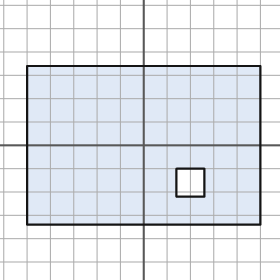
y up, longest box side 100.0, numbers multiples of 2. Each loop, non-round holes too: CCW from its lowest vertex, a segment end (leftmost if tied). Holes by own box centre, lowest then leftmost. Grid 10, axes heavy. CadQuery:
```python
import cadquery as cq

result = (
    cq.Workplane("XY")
    .moveTo(-50.0, -34.0)
    .lineTo(50.0, -34.0)
    .lineTo(50.0, 34.0)
    .lineTo(-50.0, 34.0)
    .close()
    .moveTo(14.0, -22.0)
    .lineTo(26.0, -22.0)
    .lineTo(26.0, -10.0)
    .lineTo(14.0, -10.0)
    .close()
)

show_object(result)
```